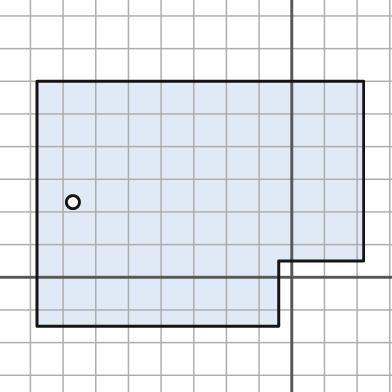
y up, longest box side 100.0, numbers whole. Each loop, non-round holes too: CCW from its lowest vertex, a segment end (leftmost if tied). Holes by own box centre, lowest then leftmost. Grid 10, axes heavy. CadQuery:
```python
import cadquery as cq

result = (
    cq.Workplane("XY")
    .moveTo(-78.0, -15.0)
    .lineTo(-4.0, -15.0)
    .lineTo(-4.0, 5.0)
    .lineTo(22.0, 5.0)
    .lineTo(22.0, 60.0)
    .lineTo(-78.0, 60.0)
    .close()
    .moveTo(-67.0, 23.0)
    .circle(2.0)
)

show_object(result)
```